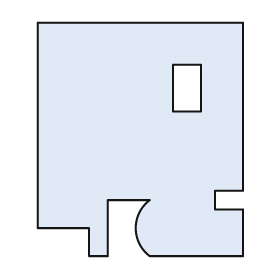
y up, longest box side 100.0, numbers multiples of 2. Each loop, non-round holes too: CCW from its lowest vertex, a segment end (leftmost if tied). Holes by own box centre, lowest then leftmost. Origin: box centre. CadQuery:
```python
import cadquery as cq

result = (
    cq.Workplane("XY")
    .moveTo(-22.0, -50.0)
    .lineTo(-14.0, -50.0)
    .lineTo(-14.0, -26.0)
    .lineTo(4.0, -26.0)
    .threePointArc((-2.0, -38.0), (4.0, -50.0))
    .lineTo(44.0, -50.0)
    .lineTo(44.0, -30.0)
    .lineTo(32.0, -30.0)
    .lineTo(32.0, -22.0)
    .lineTo(44.0, -22.0)
    .lineTo(44.0, 50.0)
    .lineTo(-44.0, 50.0)
    .lineTo(-44.0, -38.0)
    .lineTo(-22.0, -38.0)
    .close()
    .moveTo(14.0, 12.0)
    .lineTo(26.0, 12.0)
    .lineTo(26.0, 32.0)
    .lineTo(14.0, 32.0)
    .close()
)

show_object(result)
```